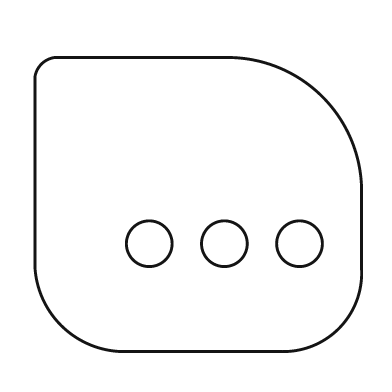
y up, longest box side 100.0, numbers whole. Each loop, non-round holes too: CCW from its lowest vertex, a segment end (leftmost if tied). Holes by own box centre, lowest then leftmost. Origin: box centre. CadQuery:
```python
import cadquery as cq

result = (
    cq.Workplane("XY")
    .moveTo(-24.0, -45.0)
    .lineTo(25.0, -45.0)
    .threePointArc((43.0, -38.0), (50.0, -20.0))
    .lineTo(50.0, 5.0)
    .threePointArc((38.0, 33.0), (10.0, 45.0))
    .lineTo(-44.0, 45.0)
    .threePointArc((-48.0, 43.0), (-50.0, 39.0))
    .lineTo(-50.0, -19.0)
    .threePointArc((-42.0, -37.0), (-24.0, -45.0))
    .close()
    .moveTo(-15.0, -12.0)
    .circle(7.0)
    .moveTo(8.0, -12.0)
    .circle(7.0)
    .moveTo(31.0, -12.0)
    .circle(7.0)
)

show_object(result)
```